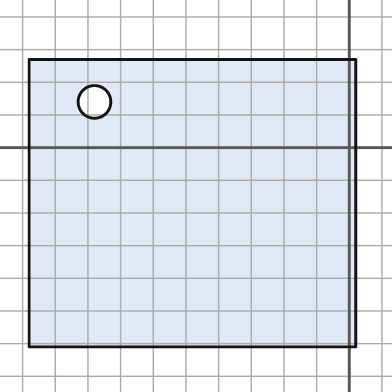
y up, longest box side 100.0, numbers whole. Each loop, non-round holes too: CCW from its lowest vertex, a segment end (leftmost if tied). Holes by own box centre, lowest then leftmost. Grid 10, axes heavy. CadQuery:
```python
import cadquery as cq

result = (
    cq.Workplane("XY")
    .moveTo(-98.0, -61.0)
    .lineTo(2.0, -61.0)
    .lineTo(2.0, 27.0)
    .lineTo(-98.0, 27.0)
    .close()
    .moveTo(-78.0, 14.0)
    .circle(5.0)
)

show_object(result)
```